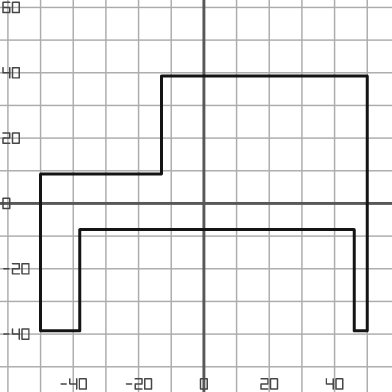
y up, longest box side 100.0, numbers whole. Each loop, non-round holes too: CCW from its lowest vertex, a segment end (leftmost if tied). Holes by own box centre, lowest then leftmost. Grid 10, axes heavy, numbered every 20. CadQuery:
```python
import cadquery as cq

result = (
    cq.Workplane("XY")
    .moveTo(-50.0, -39.0)
    .lineTo(-38.0, -39.0)
    .lineTo(-38.0, -8.0)
    .lineTo(46.0, -8.0)
    .lineTo(46.0, -39.0)
    .lineTo(50.0, -39.0)
    .lineTo(50.0, 39.0)
    .lineTo(-13.0, 39.0)
    .lineTo(-13.0, 9.0)
    .lineTo(-50.0, 9.0)
    .close()
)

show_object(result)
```